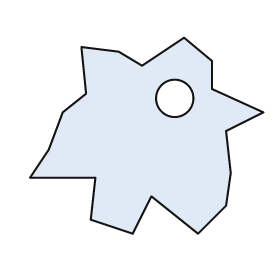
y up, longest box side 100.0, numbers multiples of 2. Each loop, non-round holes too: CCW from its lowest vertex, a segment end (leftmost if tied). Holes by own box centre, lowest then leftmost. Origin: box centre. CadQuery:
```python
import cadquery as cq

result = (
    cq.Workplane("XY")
    .moveTo(-6.0, -42.0)
    .lineTo(2.0, -26.0)
    .lineTo(22.0, -42.0)
    .lineTo(34.0, -30.0)
    .lineTo(36.0, -16.0)
    .lineTo(34.0, 2.0)
    .lineTo(50.0, 10.0)
    .lineTo(28.0, 20.0)
    .lineTo(28.0, 32.0)
    .lineTo(16.0, 42.0)
    .lineTo(-2.0, 30.0)
    .lineTo(-12.0, 36.0)
    .lineTo(-28.0, 38.0)
    .lineTo(-26.0, 18.0)
    .lineTo(-36.0, 10.0)
    .lineTo(-42.0, -6.0)
    .lineTo(-50.0, -18.0)
    .lineTo(-22.0, -18.0)
    .lineTo(-24.0, -36.0)
    .close()
    .moveTo(12.0, 16.0)
    .circle(8.0)
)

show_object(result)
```